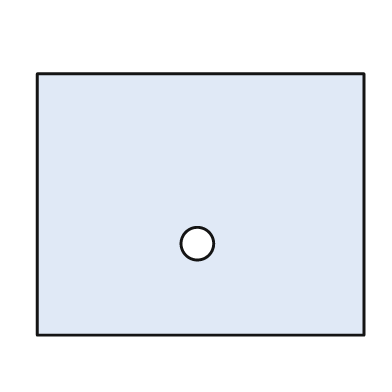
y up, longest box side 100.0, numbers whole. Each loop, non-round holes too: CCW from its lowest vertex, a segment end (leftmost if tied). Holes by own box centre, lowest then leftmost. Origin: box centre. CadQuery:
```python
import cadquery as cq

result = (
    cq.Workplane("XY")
    .moveTo(-50.0, -40.0)
    .lineTo(50.0, -40.0)
    .lineTo(50.0, 40.0)
    .lineTo(-50.0, 40.0)
    .close()
    .moveTo(-1.0, -12.0)
    .circle(5.0)
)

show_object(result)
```